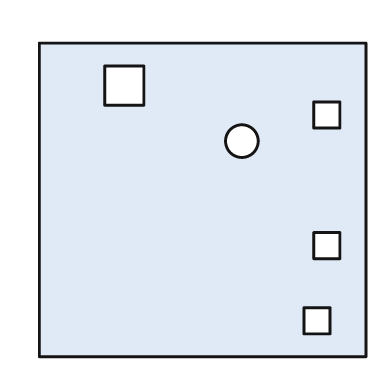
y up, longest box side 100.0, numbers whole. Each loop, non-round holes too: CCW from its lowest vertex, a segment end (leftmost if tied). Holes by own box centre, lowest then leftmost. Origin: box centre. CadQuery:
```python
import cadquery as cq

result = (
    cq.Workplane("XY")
    .moveTo(-50.0, -48.0)
    .lineTo(50.0, -48.0)
    .lineTo(50.0, 48.0)
    .lineTo(-50.0, 48.0)
    .close()
    .moveTo(31.0, -41.0)
    .lineTo(39.0, -41.0)
    .lineTo(39.0, -33.0)
    .lineTo(31.0, -33.0)
    .close()
    .moveTo(34.0, -18.0)
    .lineTo(42.0, -18.0)
    .lineTo(42.0, -10.0)
    .lineTo(34.0, -10.0)
    .close()
    .moveTo(12.0, 18.0)
    .circle(5.0)
    .moveTo(34.0, 22.0)
    .lineTo(42.0, 22.0)
    .lineTo(42.0, 30.0)
    .lineTo(34.0, 30.0)
    .close()
    .moveTo(-30.0, 29.0)
    .lineTo(-18.0, 29.0)
    .lineTo(-18.0, 41.0)
    .lineTo(-30.0, 41.0)
    .close()
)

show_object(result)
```